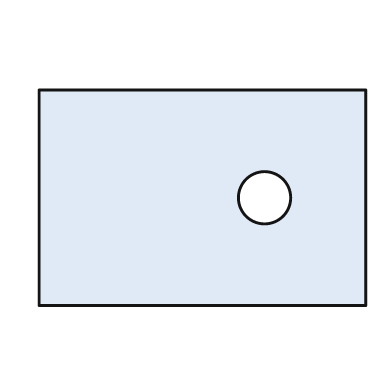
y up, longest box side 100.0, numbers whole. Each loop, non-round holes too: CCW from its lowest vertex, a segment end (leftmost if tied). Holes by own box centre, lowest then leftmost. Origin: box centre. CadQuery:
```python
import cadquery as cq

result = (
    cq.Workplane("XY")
    .moveTo(-50.0, -33.0)
    .lineTo(50.0, -33.0)
    .lineTo(50.0, 33.0)
    .lineTo(-50.0, 33.0)
    .close()
    .moveTo(19.0, 0.0)
    .circle(8.0)
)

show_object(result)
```